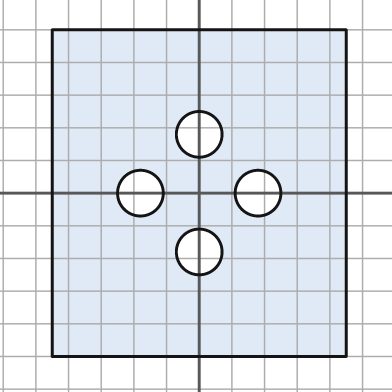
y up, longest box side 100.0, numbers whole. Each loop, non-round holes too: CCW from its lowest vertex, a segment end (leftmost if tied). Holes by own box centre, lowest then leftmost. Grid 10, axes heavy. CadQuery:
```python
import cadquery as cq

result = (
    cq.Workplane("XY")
    .moveTo(-45.0, -50.0)
    .lineTo(45.0, -50.0)
    .lineTo(45.0, 50.0)
    .lineTo(-45.0, 50.0)
    .close()
    .moveTo(0.0, -18.0)
    .circle(7.0)
    .moveTo(-18.0, 0.0)
    .circle(7.0)
    .moveTo(18.0, 0.0)
    .circle(7.0)
    .moveTo(0.0, 18.0)
    .circle(7.0)
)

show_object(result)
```